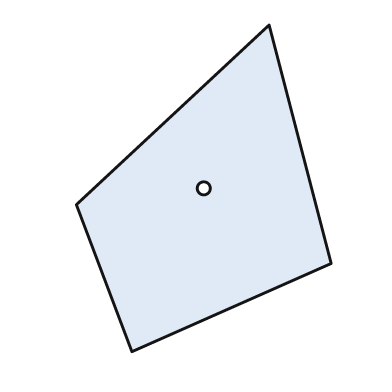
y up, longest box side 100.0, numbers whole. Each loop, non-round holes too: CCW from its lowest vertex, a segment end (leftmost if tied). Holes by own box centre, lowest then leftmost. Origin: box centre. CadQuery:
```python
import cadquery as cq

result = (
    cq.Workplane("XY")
    .moveTo(-22.0, -50.0)
    .lineTo(39.0, -23.0)
    .lineTo(20.0, 50.0)
    .lineTo(-39.0, -5.0)
    .close()
    .moveTo(0.0, 0.0)
    .circle(2.0)
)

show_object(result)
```